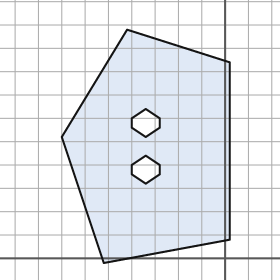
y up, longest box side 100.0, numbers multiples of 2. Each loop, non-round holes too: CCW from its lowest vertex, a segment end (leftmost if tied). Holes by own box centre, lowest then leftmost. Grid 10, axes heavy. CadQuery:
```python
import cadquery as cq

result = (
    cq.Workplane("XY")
    .moveTo(-52.0, -2.0)
    .lineTo(2.0, 8.0)
    .lineTo(2.0, 84.0)
    .lineTo(-42.0, 98.0)
    .lineTo(-70.0, 52.0)
    .close()
    .moveTo(-34.0, 32.0)
    .lineTo(-28.0, 36.0)
    .lineTo(-28.0, 40.0)
    .lineTo(-34.0, 44.0)
    .lineTo(-40.0, 40.0)
    .lineTo(-40.0, 36.0)
    .close()
    .moveTo(-34.0, 52.0)
    .lineTo(-28.0, 56.0)
    .lineTo(-28.0, 60.0)
    .lineTo(-34.0, 64.0)
    .lineTo(-40.0, 60.0)
    .lineTo(-40.0, 56.0)
    .close()
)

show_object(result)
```